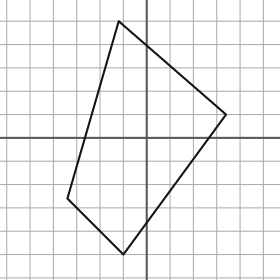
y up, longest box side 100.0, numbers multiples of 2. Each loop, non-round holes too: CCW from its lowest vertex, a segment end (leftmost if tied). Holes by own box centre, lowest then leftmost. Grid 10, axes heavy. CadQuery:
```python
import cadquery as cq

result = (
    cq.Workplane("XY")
    .moveTo(-10.0, -50.0)
    .lineTo(34.0, 10.0)
    .lineTo(-12.0, 50.0)
    .lineTo(-34.0, -26.0)
    .close()
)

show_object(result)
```